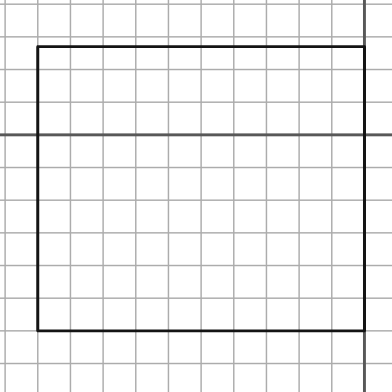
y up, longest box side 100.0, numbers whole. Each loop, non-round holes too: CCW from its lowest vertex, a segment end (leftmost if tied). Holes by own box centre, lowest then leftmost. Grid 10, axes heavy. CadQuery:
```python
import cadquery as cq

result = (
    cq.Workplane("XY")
    .moveTo(-100.0, -60.0)
    .lineTo(0.0, -60.0)
    .lineTo(0.0, 27.0)
    .lineTo(-100.0, 27.0)
    .close()
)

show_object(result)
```